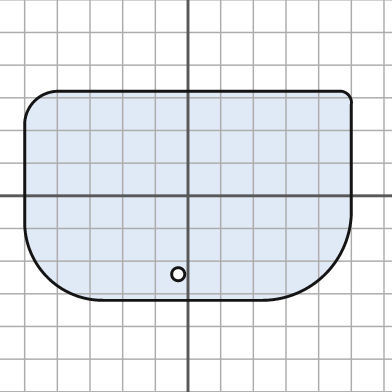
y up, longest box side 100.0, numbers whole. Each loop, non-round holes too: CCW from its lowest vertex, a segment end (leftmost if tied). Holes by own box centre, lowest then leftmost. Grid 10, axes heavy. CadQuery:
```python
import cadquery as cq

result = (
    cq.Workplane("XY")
    .moveTo(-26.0, -32.0)
    .lineTo(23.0, -32.0)
    .threePointArc((42.0, -24.0), (50.0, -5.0))
    .lineTo(50.0, 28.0)
    .threePointArc((49.0, 31.0), (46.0, 32.0))
    .lineTo(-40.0, 32.0)
    .threePointArc((-47.0, 29.0), (-50.0, 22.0))
    .lineTo(-50.0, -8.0)
    .threePointArc((-43.0, -25.0), (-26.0, -32.0))
    .close()
    .moveTo(-3.0, -24.0)
    .circle(2.0)
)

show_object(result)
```